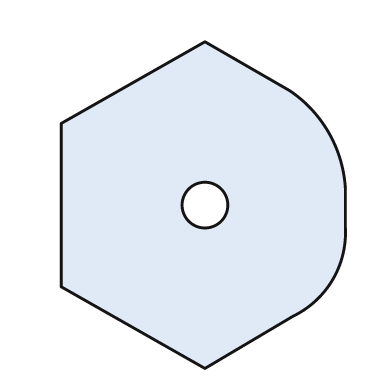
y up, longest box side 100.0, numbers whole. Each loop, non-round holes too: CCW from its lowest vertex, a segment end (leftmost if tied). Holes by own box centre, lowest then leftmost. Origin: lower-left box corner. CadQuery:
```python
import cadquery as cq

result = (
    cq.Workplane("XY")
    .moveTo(44.0, 0.0)
    .lineTo(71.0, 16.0)
    .threePointArc((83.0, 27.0), (87.0, 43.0))
    .lineTo(87.0, 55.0)
    .threePointArc((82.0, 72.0), (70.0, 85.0))
    .lineTo(44.0, 100.0)
    .lineTo(0.0, 75.0)
    .lineTo(0.0, 25.0)
    .close()
    .moveTo(44.0, 50.0)
    .circle(7.0)
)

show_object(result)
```